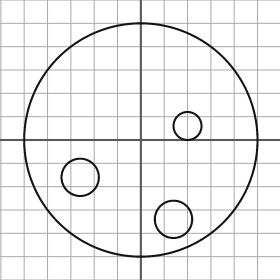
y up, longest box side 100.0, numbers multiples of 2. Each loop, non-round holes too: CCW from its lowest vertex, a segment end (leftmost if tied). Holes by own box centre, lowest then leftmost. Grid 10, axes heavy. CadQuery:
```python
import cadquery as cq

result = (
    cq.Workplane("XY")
    .moveTo(0.0, 0.0)
    .circle(50.0)
    .moveTo(14.0, -34.0)
    .circle(8.0)
    .moveTo(-26.0, -16.0)
    .circle(8.0)
    .moveTo(20.0, 6.0)
    .circle(6.0)
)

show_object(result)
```